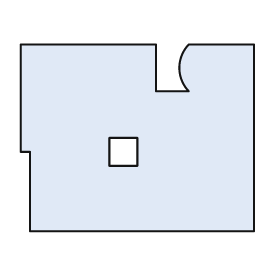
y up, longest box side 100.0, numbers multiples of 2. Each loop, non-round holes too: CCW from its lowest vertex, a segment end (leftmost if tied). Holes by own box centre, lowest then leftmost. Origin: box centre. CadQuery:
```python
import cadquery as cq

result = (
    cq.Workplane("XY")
    .moveTo(-46.0, -40.0)
    .lineTo(50.0, -40.0)
    .lineTo(50.0, 40.0)
    .lineTo(22.0, 40.0)
    .threePointArc((18.0, 30.0), (22.0, 20.0))
    .lineTo(8.0, 20.0)
    .lineTo(8.0, 40.0)
    .lineTo(-50.0, 40.0)
    .lineTo(-50.0, -6.0)
    .lineTo(-46.0, -6.0)
    .close()
    .moveTo(-12.0, -12.0)
    .lineTo(0.0, -12.0)
    .lineTo(0.0, 0.0)
    .lineTo(-12.0, 0.0)
    .close()
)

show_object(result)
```